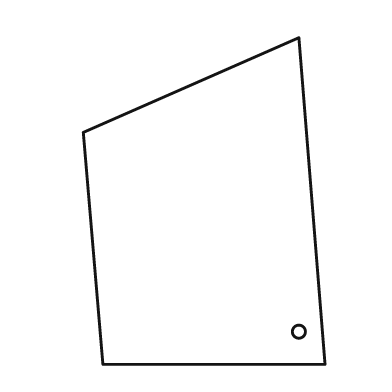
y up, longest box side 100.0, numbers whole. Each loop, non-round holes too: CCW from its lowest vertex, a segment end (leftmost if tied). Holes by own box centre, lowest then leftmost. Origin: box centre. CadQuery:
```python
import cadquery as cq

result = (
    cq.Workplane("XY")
    .moveTo(-31.0, -50.0)
    .lineTo(37.0, -50.0)
    .lineTo(29.0, 50.0)
    .lineTo(-37.0, 21.0)
    .close()
    .moveTo(29.0, -40.0)
    .circle(2.0)
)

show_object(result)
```